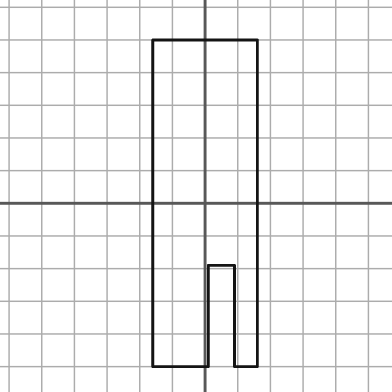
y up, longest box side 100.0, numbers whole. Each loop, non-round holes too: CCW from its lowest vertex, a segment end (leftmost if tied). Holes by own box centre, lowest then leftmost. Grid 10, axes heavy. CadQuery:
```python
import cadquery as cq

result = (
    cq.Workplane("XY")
    .moveTo(-16.0, -50.0)
    .lineTo(1.0, -50.0)
    .lineTo(1.0, -19.0)
    .lineTo(9.0, -19.0)
    .lineTo(9.0, -50.0)
    .lineTo(16.0, -50.0)
    .lineTo(16.0, 50.0)
    .lineTo(-16.0, 50.0)
    .close()
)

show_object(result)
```